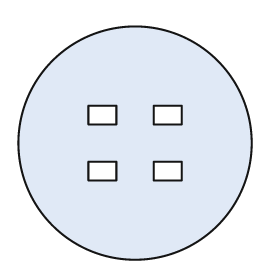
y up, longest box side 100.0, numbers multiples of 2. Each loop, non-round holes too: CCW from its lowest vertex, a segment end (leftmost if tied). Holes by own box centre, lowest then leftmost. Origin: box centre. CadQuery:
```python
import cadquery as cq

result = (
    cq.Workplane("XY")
    .moveTo(0.0, 0.0)
    .circle(50.0)
    .moveTo(-20.0, -16.0)
    .lineTo(-8.0, -16.0)
    .lineTo(-8.0, -8.0)
    .lineTo(-20.0, -8.0)
    .close()
    .moveTo(8.0, -16.0)
    .lineTo(20.0, -16.0)
    .lineTo(20.0, -8.0)
    .lineTo(8.0, -8.0)
    .close()
    .moveTo(-20.0, 8.0)
    .lineTo(-8.0, 8.0)
    .lineTo(-8.0, 16.0)
    .lineTo(-20.0, 16.0)
    .close()
    .moveTo(8.0, 8.0)
    .lineTo(20.0, 8.0)
    .lineTo(20.0, 16.0)
    .lineTo(8.0, 16.0)
    .close()
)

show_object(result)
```